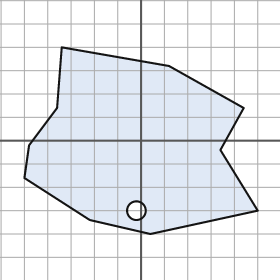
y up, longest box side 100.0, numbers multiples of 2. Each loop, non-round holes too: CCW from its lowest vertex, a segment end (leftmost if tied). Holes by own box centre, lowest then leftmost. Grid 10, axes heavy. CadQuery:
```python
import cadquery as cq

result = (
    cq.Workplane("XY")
    .moveTo(4.0, -40.0)
    .lineTo(50.0, -30.0)
    .lineTo(34.0, -4.0)
    .lineTo(44.0, 14.0)
    .lineTo(12.0, 32.0)
    .lineTo(-34.0, 40.0)
    .lineTo(-36.0, 14.0)
    .lineTo(-48.0, -2.0)
    .lineTo(-50.0, -16.0)
    .lineTo(-22.0, -34.0)
    .close()
    .moveTo(-2.0, -30.0)
    .circle(4.0)
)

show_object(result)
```